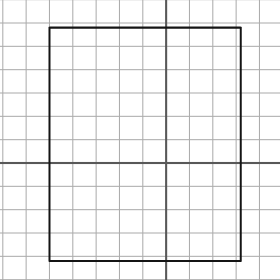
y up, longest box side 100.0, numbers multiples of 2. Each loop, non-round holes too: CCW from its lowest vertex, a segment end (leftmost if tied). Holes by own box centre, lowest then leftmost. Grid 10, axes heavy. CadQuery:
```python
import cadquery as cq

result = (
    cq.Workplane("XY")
    .moveTo(-50.0, -42.0)
    .lineTo(32.0, -42.0)
    .lineTo(32.0, 58.0)
    .lineTo(-50.0, 58.0)
    .close()
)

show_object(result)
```